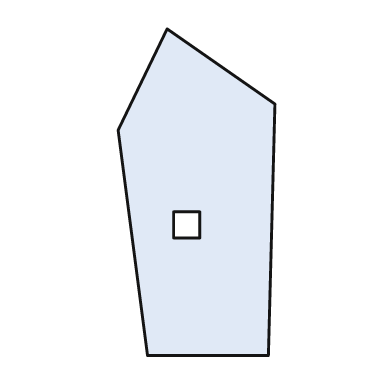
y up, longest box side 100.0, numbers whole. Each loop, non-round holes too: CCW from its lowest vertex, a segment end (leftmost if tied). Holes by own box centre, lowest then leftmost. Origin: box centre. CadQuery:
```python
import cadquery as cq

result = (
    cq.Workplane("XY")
    .moveTo(-15.0, -50.0)
    .lineTo(22.0, -50.0)
    .lineTo(24.0, 27.0)
    .lineTo(-9.0, 50.0)
    .lineTo(-24.0, 19.0)
    .close()
    .moveTo(-7.0, -14.0)
    .lineTo(1.0, -14.0)
    .lineTo(1.0, -6.0)
    .lineTo(-7.0, -6.0)
    .close()
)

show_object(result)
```